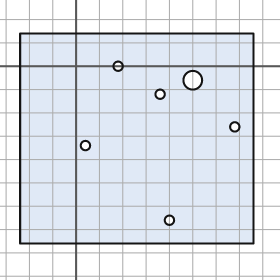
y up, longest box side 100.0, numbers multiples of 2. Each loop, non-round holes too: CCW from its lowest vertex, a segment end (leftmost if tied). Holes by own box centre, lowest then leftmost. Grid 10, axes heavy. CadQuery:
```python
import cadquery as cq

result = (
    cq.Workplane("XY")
    .moveTo(-24.0, -76.0)
    .lineTo(76.0, -76.0)
    .lineTo(76.0, 14.0)
    .lineTo(-24.0, 14.0)
    .close()
    .moveTo(40.0, -66.0)
    .circle(2.0)
    .moveTo(4.0, -34.0)
    .circle(2.0)
    .moveTo(68.0, -26.0)
    .circle(2.0)
    .moveTo(36.0, -12.0)
    .circle(2.0)
    .moveTo(50.0, -6.0)
    .circle(4.0)
    .moveTo(18.0, 0.0)
    .circle(2.0)
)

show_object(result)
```